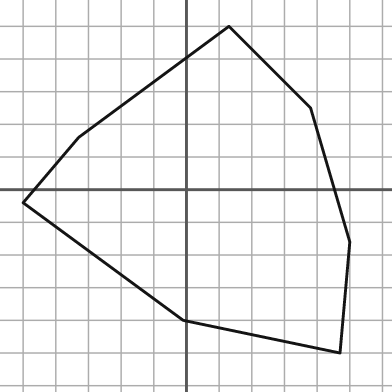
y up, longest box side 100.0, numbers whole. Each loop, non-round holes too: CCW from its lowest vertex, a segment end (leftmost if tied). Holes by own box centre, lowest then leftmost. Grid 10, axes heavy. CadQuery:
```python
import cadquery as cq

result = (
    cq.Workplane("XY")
    .moveTo(47.0, -50.0)
    .lineTo(50.0, -16.0)
    .lineTo(38.0, 25.0)
    .lineTo(13.0, 50.0)
    .lineTo(-33.0, 16.0)
    .lineTo(-50.0, -4.0)
    .lineTo(-1.0, -40.0)
    .close()
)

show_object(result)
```